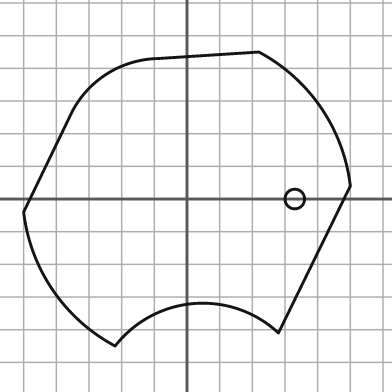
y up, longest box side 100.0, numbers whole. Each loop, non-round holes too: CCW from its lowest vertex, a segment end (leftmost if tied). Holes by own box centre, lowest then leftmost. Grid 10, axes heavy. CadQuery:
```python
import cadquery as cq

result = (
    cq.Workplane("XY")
    .moveTo(-22.0, -45.0)
    .threePointArc((2.0, -32.0), (28.0, -41.0))
    .lineTo(50.0, 4.0)
    .threePointArc((41.0, 28.0), (22.0, 45.0))
    .lineTo(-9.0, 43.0)
    .threePointArc((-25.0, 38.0), (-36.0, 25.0))
    .lineTo(-50.0, -4.0)
    .threePointArc((-41.0, -28.0), (-22.0, -45.0))
    .close()
    .moveTo(33.0, 0.0)
    .circle(3.0)
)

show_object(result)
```